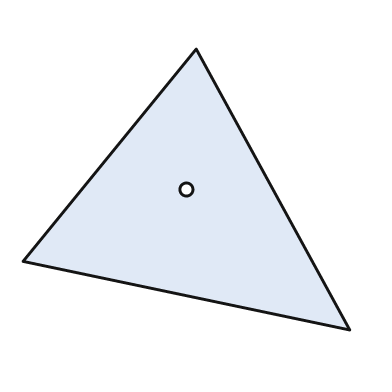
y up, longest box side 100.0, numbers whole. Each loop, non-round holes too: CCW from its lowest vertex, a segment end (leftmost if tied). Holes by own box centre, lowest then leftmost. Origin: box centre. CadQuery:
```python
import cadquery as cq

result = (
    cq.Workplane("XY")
    .moveTo(50.0, -43.0)
    .lineTo(3.0, 43.0)
    .lineTo(-50.0, -22.0)
    .close()
    .moveTo(0.0, 0.0)
    .circle(2.0)
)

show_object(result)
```